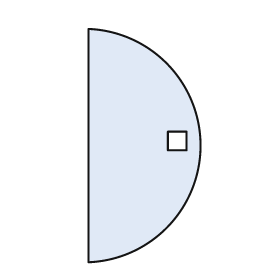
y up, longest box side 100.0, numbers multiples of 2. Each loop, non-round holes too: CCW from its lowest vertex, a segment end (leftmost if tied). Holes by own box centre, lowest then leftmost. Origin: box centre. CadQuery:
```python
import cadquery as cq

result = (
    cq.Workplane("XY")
    .moveTo(-24.0, -50.0)
    .threePointArc((24.0, 0.0), (-24.0, 50.0))
    .close()
    .moveTo(10.0, -2.0)
    .lineTo(18.0, -2.0)
    .lineTo(18.0, 6.0)
    .lineTo(10.0, 6.0)
    .close()
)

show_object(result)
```